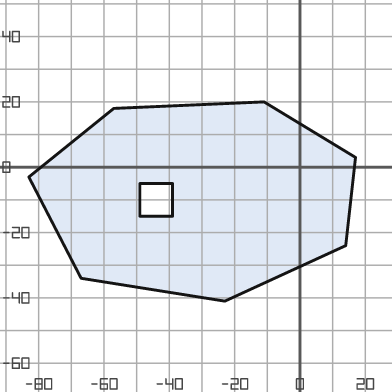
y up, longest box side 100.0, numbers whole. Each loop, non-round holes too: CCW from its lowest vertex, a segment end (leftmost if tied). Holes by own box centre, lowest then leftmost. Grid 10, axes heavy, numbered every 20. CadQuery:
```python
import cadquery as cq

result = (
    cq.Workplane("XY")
    .moveTo(-23.0, -41.0)
    .lineTo(14.0, -24.0)
    .lineTo(17.0, 3.0)
    .lineTo(-11.0, 20.0)
    .lineTo(-57.0, 18.0)
    .lineTo(-83.0, -3.0)
    .lineTo(-67.0, -34.0)
    .close()
    .moveTo(-49.0, -15.0)
    .lineTo(-39.0, -15.0)
    .lineTo(-39.0, -5.0)
    .lineTo(-49.0, -5.0)
    .close()
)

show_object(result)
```